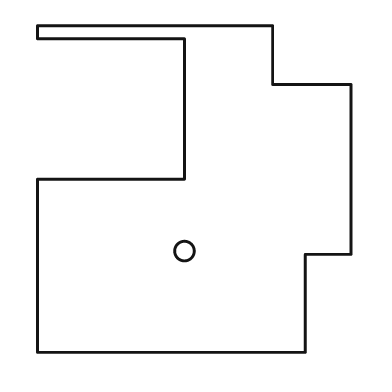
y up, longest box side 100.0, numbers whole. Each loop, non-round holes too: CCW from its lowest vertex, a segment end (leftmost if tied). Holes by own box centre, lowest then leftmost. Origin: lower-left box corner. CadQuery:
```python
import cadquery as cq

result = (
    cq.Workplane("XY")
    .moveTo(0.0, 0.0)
    .lineTo(82.0, 0.0)
    .lineTo(82.0, 30.0)
    .lineTo(96.0, 30.0)
    .lineTo(96.0, 82.0)
    .lineTo(72.0, 82.0)
    .lineTo(72.0, 100.0)
    .lineTo(0.0, 100.0)
    .lineTo(0.0, 96.0)
    .lineTo(45.0, 96.0)
    .lineTo(45.0, 53.0)
    .lineTo(0.0, 53.0)
    .close()
    .moveTo(45.0, 31.0)
    .circle(3.0)
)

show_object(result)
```